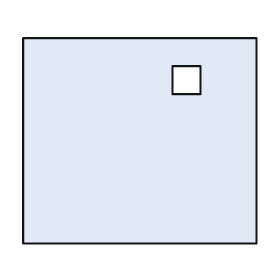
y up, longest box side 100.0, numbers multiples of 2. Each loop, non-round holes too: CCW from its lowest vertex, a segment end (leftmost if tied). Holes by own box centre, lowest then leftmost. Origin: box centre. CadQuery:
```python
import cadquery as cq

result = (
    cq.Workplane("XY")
    .moveTo(-50.0, -44.0)
    .lineTo(50.0, -44.0)
    .lineTo(50.0, 44.0)
    .lineTo(-50.0, 44.0)
    .close()
    .moveTo(14.0, 20.0)
    .lineTo(26.0, 20.0)
    .lineTo(26.0, 32.0)
    .lineTo(14.0, 32.0)
    .close()
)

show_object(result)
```